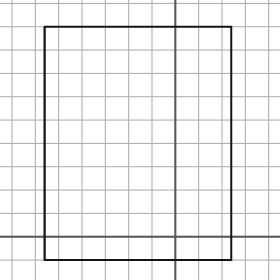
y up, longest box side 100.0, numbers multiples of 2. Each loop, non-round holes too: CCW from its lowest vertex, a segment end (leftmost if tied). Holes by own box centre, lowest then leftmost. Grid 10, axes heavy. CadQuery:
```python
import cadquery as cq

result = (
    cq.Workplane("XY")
    .moveTo(-56.0, -10.0)
    .lineTo(24.0, -10.0)
    .lineTo(24.0, 90.0)
    .lineTo(-56.0, 90.0)
    .close()
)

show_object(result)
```